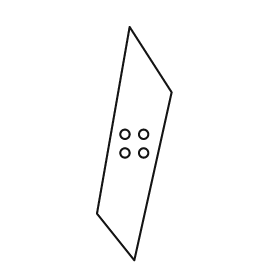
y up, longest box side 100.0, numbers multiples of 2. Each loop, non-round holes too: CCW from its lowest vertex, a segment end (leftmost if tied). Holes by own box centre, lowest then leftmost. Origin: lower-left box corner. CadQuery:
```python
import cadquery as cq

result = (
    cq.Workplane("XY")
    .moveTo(16.0, 0.0)
    .lineTo(32.0, 72.0)
    .lineTo(14.0, 100.0)
    .lineTo(0.0, 20.0)
    .close()
    .moveTo(12.0, 46.0)
    .circle(2.0)
    .moveTo(20.0, 46.0)
    .circle(2.0)
    .moveTo(12.0, 54.0)
    .circle(2.0)
    .moveTo(20.0, 54.0)
    .circle(2.0)
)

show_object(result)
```